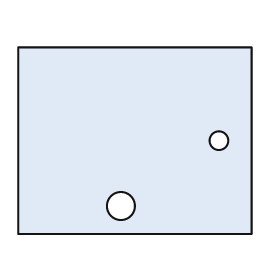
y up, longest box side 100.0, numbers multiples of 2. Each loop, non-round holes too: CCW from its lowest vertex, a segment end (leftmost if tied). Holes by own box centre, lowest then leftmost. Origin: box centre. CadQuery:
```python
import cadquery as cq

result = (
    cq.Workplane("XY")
    .moveTo(-50.0, -40.0)
    .lineTo(50.0, -40.0)
    .lineTo(50.0, 40.0)
    .lineTo(-50.0, 40.0)
    .close()
    .moveTo(-6.0, -28.0)
    .circle(6.0)
    .moveTo(36.0, 0.0)
    .circle(4.0)
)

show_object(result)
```